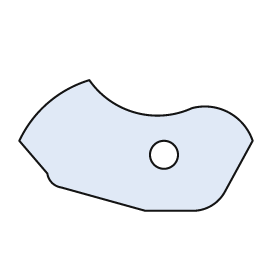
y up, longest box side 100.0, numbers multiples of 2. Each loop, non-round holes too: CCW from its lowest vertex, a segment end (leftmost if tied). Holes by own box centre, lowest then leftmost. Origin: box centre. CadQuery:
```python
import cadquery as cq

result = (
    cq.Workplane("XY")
    .moveTo(4.0, -28.0)
    .lineTo(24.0, -28.0)
    .threePointArc((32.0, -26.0), (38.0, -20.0))
    .lineTo(50.0, 2.0)
    .threePointArc((40.0, 14.0), (24.0, 16.0))
    .threePointArc((0.0, 14.0), (-20.0, 28.0))
    .threePointArc((-38.0, 18.0), (-50.0, 2.0))
    .lineTo(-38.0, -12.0)
    .threePointArc((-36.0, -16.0), (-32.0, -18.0))
    .close()
    .moveTo(12.0, -4.0)
    .circle(6.0)
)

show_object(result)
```